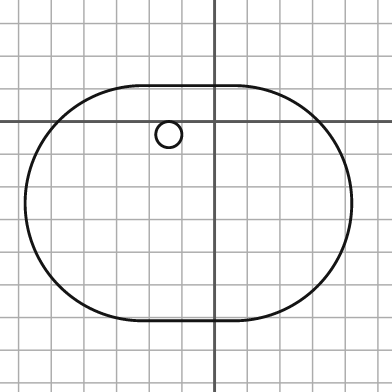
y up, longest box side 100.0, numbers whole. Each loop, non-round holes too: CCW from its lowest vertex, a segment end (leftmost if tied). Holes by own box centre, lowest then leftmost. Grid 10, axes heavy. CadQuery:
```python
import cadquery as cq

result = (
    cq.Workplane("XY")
    .moveTo(-22.0, -61.0)
    .lineTo(6.0, -61.0)
    .threePointArc((42.0, -25.0), (6.0, 11.0))
    .lineTo(-22.0, 11.0)
    .threePointArc((-58.0, -25.0), (-22.0, -61.0))
    .close()
    .moveTo(-14.0, -4.0)
    .circle(4.0)
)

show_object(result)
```